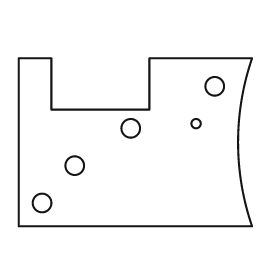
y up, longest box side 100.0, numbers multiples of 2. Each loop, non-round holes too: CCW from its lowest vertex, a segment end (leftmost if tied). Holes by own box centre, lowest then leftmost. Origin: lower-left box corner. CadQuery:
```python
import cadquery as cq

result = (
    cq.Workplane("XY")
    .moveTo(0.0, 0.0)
    .lineTo(100.0, 0.0)
    .threePointArc((94.0, 36.0), (100.0, 72.0))
    .lineTo(56.0, 72.0)
    .lineTo(56.0, 50.0)
    .lineTo(14.0, 50.0)
    .lineTo(14.0, 72.0)
    .lineTo(0.0, 72.0)
    .close()
    .moveTo(10.0, 10.0)
    .circle(4.0)
    .moveTo(24.0, 26.0)
    .circle(4.0)
    .moveTo(48.0, 42.0)
    .circle(4.0)
    .moveTo(76.0, 44.0)
    .circle(2.0)
    .moveTo(84.0, 60.0)
    .circle(4.0)
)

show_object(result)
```